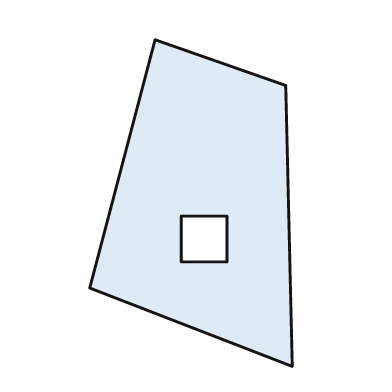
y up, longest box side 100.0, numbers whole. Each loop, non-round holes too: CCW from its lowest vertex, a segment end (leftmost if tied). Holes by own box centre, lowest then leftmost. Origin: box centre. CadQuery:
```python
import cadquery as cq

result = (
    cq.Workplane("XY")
    .moveTo(31.0, -50.0)
    .lineTo(29.0, 36.0)
    .lineTo(-11.0, 50.0)
    .lineTo(-31.0, -26.0)
    .close()
    .moveTo(-3.0, -18.0)
    .lineTo(11.0, -18.0)
    .lineTo(11.0, -4.0)
    .lineTo(-3.0, -4.0)
    .close()
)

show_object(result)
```